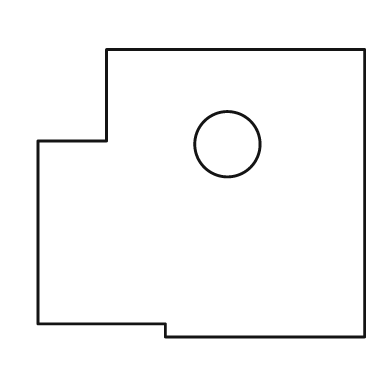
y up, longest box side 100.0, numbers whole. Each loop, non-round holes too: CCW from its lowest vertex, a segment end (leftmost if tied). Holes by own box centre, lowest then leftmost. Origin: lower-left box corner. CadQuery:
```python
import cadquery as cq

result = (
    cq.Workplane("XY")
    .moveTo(39.0, 0.0)
    .lineTo(100.0, 0.0)
    .lineTo(100.0, 88.0)
    .lineTo(21.0, 88.0)
    .lineTo(21.0, 60.0)
    .lineTo(0.0, 60.0)
    .lineTo(0.0, 4.0)
    .lineTo(39.0, 4.0)
    .close()
    .moveTo(58.0, 59.0)
    .circle(10.0)
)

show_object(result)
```